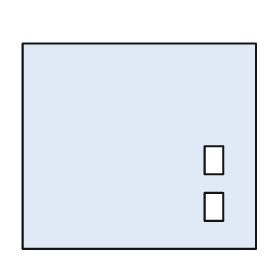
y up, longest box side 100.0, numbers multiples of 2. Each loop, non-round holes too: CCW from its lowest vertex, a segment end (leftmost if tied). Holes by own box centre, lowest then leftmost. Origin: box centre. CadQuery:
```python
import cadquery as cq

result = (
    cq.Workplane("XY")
    .moveTo(-50.0, -44.0)
    .lineTo(50.0, -44.0)
    .lineTo(50.0, 44.0)
    .lineTo(-50.0, 44.0)
    .close()
    .moveTo(28.0, -32.0)
    .lineTo(36.0, -32.0)
    .lineTo(36.0, -20.0)
    .lineTo(28.0, -20.0)
    .close()
    .moveTo(28.0, -12.0)
    .lineTo(36.0, -12.0)
    .lineTo(36.0, 0.0)
    .lineTo(28.0, 0.0)
    .close()
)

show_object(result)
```